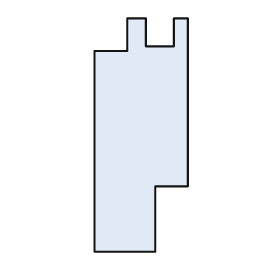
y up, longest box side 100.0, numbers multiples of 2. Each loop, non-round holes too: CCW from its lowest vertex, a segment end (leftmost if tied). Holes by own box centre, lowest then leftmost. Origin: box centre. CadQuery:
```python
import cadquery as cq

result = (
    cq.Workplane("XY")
    .moveTo(-20.0, -50.0)
    .lineTo(6.0, -50.0)
    .lineTo(6.0, -22.0)
    .lineTo(20.0, -22.0)
    .lineTo(20.0, 50.0)
    .lineTo(14.0, 50.0)
    .lineTo(14.0, 38.0)
    .lineTo(2.0, 38.0)
    .lineTo(2.0, 50.0)
    .lineTo(-6.0, 50.0)
    .lineTo(-6.0, 36.0)
    .lineTo(-20.0, 36.0)
    .close()
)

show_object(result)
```